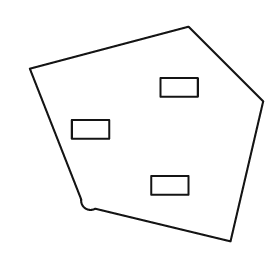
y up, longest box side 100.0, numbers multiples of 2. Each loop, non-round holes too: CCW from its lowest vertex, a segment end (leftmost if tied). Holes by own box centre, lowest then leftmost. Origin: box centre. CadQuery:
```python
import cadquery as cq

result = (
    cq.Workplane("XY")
    .moveTo(36.0, -46.0)
    .lineTo(50.0, 14.0)
    .lineTo(18.0, 46.0)
    .lineTo(-50.0, 28.0)
    .lineTo(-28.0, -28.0)
    .threePointArc((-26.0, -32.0), (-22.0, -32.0))
    .close()
    .moveTo(2.0, -26.0)
    .lineTo(18.0, -26.0)
    .lineTo(18.0, -18.0)
    .lineTo(2.0, -18.0)
    .close()
    .moveTo(-32.0, -2.0)
    .lineTo(-16.0, -2.0)
    .lineTo(-16.0, 6.0)
    .lineTo(-32.0, 6.0)
    .close()
    .moveTo(6.0, 16.0)
    .lineTo(22.0, 16.0)
    .lineTo(22.0, 24.0)
    .lineTo(6.0, 24.0)
    .close()
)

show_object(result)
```